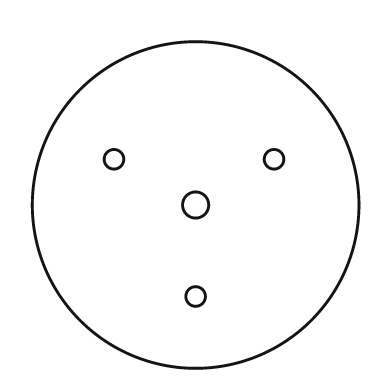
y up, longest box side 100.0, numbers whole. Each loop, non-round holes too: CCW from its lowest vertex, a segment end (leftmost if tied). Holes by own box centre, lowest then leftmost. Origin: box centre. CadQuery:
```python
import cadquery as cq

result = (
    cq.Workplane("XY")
    .moveTo(0.0, 0.0)
    .circle(50.0)
    .moveTo(0.0, -28.0)
    .circle(3.0)
    .moveTo(0.0, 0.0)
    .circle(4.0)
    .moveTo(-25.0, 14.0)
    .circle(3.0)
    .moveTo(24.0, 14.0)
    .circle(3.0)
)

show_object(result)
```